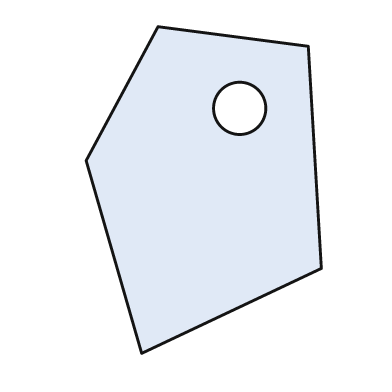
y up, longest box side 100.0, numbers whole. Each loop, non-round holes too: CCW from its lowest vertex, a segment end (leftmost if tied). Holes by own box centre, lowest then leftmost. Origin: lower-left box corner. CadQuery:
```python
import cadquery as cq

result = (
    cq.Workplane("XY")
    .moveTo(17.0, 0.0)
    .lineTo(72.0, 26.0)
    .lineTo(68.0, 94.0)
    .lineTo(22.0, 100.0)
    .lineTo(0.0, 59.0)
    .close()
    .moveTo(47.0, 75.0)
    .circle(8.0)
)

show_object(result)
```